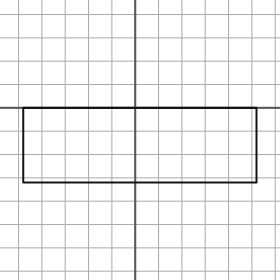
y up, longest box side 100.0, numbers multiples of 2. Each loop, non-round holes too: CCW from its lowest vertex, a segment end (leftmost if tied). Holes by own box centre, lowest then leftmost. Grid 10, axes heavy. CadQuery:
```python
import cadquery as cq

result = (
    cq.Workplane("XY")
    .moveTo(-48.0, -32.0)
    .lineTo(52.0, -32.0)
    .lineTo(52.0, 0.0)
    .lineTo(-48.0, 0.0)
    .close()
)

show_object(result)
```